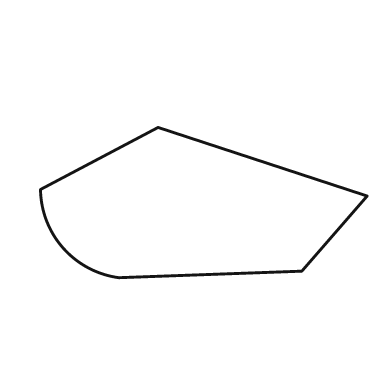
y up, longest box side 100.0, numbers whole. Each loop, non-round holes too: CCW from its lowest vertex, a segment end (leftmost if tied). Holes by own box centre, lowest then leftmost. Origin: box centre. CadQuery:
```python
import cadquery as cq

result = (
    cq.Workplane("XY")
    .moveTo(-26.0, -23.0)
    .lineTo(30.0, -21.0)
    .lineTo(50.0, 2.0)
    .lineTo(-14.0, 23.0)
    .lineTo(-50.0, 4.0)
    .threePointArc((-43.0, -14.0), (-26.0, -23.0))
    .close()
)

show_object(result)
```